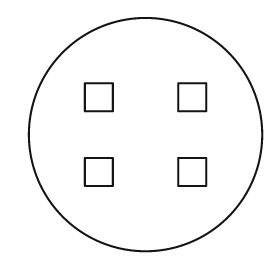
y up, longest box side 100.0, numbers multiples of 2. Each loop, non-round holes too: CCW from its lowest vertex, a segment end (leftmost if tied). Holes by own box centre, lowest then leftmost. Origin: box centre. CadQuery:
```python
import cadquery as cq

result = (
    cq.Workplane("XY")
    .moveTo(0.0, 0.0)
    .circle(50.0)
    .moveTo(-26.0, -22.0)
    .lineTo(-14.0, -22.0)
    .lineTo(-14.0, -10.0)
    .lineTo(-26.0, -10.0)
    .close()
    .moveTo(14.0, -22.0)
    .lineTo(26.0, -22.0)
    .lineTo(26.0, -10.0)
    .lineTo(14.0, -10.0)
    .close()
    .moveTo(-26.0, 10.0)
    .lineTo(-14.0, 10.0)
    .lineTo(-14.0, 22.0)
    .lineTo(-26.0, 22.0)
    .close()
    .moveTo(14.0, 10.0)
    .lineTo(26.0, 10.0)
    .lineTo(26.0, 22.0)
    .lineTo(14.0, 22.0)
    .close()
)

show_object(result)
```